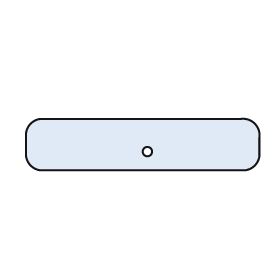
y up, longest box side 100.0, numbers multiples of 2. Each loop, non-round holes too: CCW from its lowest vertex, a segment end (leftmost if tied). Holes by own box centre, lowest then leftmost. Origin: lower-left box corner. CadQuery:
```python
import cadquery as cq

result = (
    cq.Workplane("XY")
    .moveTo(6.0, 0.0)
    .lineTo(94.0, 0.0)
    .threePointArc((98.0, 2.0), (100.0, 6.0))
    .lineTo(100.0, 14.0)
    .threePointArc((98.0, 20.0), (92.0, 22.0))
    .lineTo(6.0, 22.0)
    .threePointArc((2.0, 20.0), (0.0, 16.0))
    .lineTo(0.0, 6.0)
    .threePointArc((2.0, 2.0), (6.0, 0.0))
    .close()
    .moveTo(52.0, 8.0)
    .circle(2.0)
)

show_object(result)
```